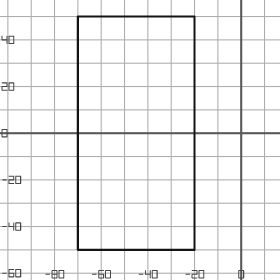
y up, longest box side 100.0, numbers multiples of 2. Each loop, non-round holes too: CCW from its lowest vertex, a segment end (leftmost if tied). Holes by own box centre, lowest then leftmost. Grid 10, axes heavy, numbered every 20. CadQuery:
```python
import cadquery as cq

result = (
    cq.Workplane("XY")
    .moveTo(-70.0, -50.0)
    .lineTo(-20.0, -50.0)
    .lineTo(-20.0, 50.0)
    .lineTo(-70.0, 50.0)
    .close()
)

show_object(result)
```